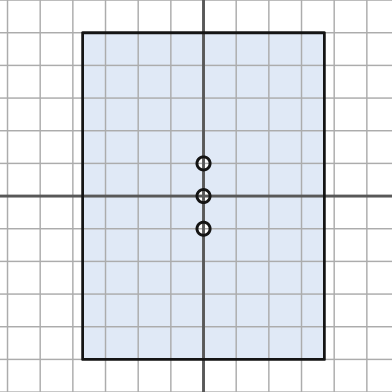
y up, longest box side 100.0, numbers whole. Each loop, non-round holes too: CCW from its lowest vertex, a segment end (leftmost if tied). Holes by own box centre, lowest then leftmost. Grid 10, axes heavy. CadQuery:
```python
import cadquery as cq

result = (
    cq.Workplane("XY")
    .moveTo(-37.0, -50.0)
    .lineTo(37.0, -50.0)
    .lineTo(37.0, 50.0)
    .lineTo(-37.0, 50.0)
    .close()
    .moveTo(0.0, -10.0)
    .circle(2.0)
    .moveTo(0.0, 0.0)
    .circle(2.0)
    .moveTo(0.0, 10.0)
    .circle(2.0)
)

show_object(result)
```